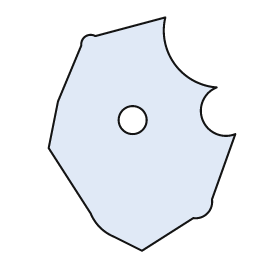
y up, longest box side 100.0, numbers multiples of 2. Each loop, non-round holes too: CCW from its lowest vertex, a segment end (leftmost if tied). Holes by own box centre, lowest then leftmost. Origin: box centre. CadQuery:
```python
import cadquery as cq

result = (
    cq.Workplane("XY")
    .moveTo(0.0, -50.0)
    .lineTo(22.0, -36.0)
    .threePointArc((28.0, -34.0), (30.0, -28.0))
    .lineTo(40.0, 0.0)
    .threePointArc((26.0, 6.0), (32.0, 20.0))
    .threePointArc((14.0, 30.0), (10.0, 50.0))
    .lineTo(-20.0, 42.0)
    .threePointArc((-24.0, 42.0), (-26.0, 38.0))
    .lineTo(-36.0, 14.0)
    .lineTo(-40.0, -6.0)
    .lineTo(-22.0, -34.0)
    .threePointArc((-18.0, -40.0), (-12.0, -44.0))
    .close()
    .moveTo(-4.0, 6.0)
    .circle(6.0)
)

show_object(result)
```